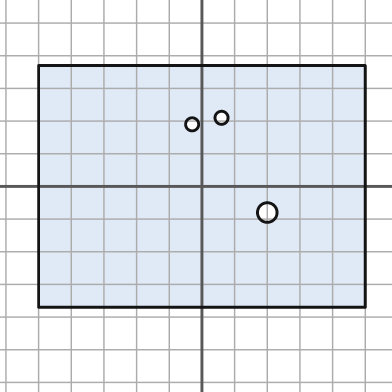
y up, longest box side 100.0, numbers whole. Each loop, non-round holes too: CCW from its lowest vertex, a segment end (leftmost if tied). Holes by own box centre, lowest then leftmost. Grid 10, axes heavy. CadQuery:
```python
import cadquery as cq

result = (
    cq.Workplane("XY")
    .moveTo(-50.0, -37.0)
    .lineTo(50.0, -37.0)
    .lineTo(50.0, 37.0)
    .lineTo(-50.0, 37.0)
    .close()
    .moveTo(20.0, -8.0)
    .circle(3.0)
    .moveTo(-3.0, 19.0)
    .circle(2.0)
    .moveTo(6.0, 21.0)
    .circle(2.0)
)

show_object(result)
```